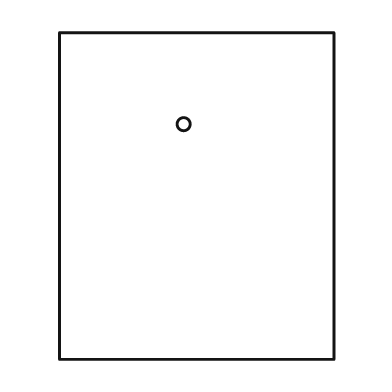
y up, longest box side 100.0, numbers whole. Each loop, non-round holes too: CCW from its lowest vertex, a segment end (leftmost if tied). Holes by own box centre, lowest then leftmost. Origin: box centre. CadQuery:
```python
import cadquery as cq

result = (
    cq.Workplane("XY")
    .moveTo(-42.0, -50.0)
    .lineTo(42.0, -50.0)
    .lineTo(42.0, 50.0)
    .lineTo(-42.0, 50.0)
    .close()
    .moveTo(-4.0, 22.0)
    .circle(2.0)
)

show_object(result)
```